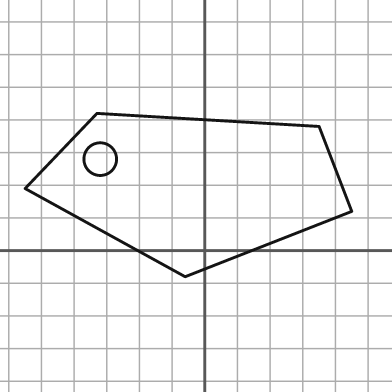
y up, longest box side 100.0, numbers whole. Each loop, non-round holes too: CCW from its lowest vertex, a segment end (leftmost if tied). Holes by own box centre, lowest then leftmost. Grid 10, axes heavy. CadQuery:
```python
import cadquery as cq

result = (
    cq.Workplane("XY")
    .moveTo(-6.0, -8.0)
    .lineTo(45.0, 12.0)
    .lineTo(35.0, 38.0)
    .lineTo(-33.0, 42.0)
    .lineTo(-55.0, 19.0)
    .close()
    .moveTo(-32.0, 28.0)
    .circle(5.0)
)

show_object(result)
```